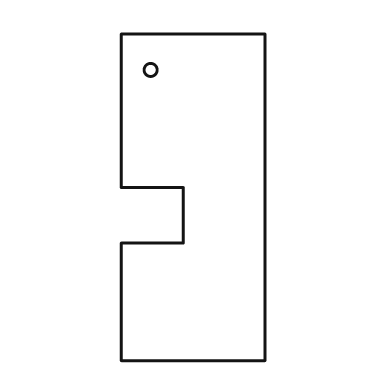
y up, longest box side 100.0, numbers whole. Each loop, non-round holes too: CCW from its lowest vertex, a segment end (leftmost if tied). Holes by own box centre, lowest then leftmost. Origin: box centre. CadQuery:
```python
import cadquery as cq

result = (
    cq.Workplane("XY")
    .moveTo(-22.0, -50.0)
    .lineTo(22.0, -50.0)
    .lineTo(22.0, 50.0)
    .lineTo(-22.0, 50.0)
    .lineTo(-22.0, 3.0)
    .lineTo(-3.0, 3.0)
    .lineTo(-3.0, -14.0)
    .lineTo(-22.0, -14.0)
    .close()
    .moveTo(-13.0, 39.0)
    .circle(2.0)
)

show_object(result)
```